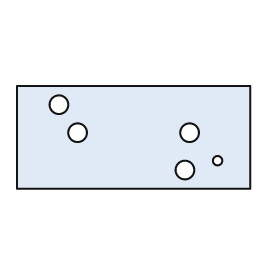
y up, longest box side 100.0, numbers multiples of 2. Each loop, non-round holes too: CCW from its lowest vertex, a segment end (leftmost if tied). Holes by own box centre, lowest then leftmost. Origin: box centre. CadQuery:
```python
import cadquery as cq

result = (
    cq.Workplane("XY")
    .moveTo(-50.0, -22.0)
    .lineTo(50.0, -22.0)
    .lineTo(50.0, 22.0)
    .lineTo(-50.0, 22.0)
    .close()
    .moveTo(22.0, -14.0)
    .circle(4.0)
    .moveTo(36.0, -10.0)
    .circle(2.0)
    .moveTo(-24.0, 2.0)
    .circle(4.0)
    .moveTo(24.0, 2.0)
    .circle(4.0)
    .moveTo(-32.0, 14.0)
    .circle(4.0)
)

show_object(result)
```